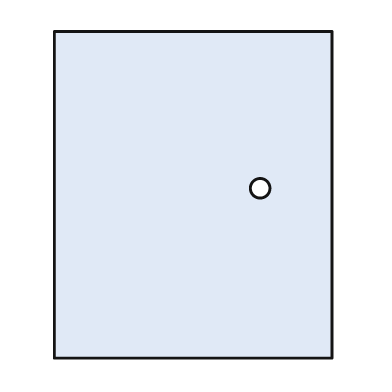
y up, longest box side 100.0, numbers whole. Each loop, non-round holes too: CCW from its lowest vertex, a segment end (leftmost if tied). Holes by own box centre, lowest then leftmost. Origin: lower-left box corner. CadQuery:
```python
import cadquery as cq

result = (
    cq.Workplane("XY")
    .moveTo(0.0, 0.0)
    .lineTo(85.0, 0.0)
    .lineTo(85.0, 100.0)
    .lineTo(0.0, 100.0)
    .close()
    .moveTo(63.0, 52.0)
    .circle(3.0)
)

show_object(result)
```